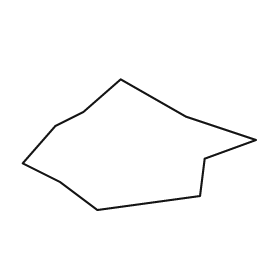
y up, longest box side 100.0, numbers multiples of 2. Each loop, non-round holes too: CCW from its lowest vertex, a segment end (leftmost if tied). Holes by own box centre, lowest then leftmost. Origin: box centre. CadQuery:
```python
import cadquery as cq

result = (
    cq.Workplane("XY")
    .moveTo(-18.0, -28.0)
    .lineTo(26.0, -22.0)
    .lineTo(28.0, -6.0)
    .lineTo(50.0, 2.0)
    .lineTo(20.0, 12.0)
    .lineTo(-8.0, 28.0)
    .lineTo(-24.0, 14.0)
    .lineTo(-36.0, 8.0)
    .lineTo(-50.0, -8.0)
    .lineTo(-34.0, -16.0)
    .close()
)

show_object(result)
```